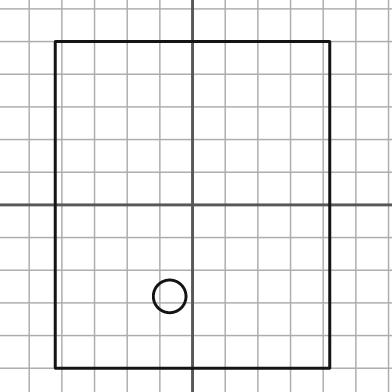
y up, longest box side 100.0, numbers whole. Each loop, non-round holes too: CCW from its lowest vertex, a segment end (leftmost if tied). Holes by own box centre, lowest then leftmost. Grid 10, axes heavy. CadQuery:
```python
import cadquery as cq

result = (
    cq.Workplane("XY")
    .moveTo(-42.0, -50.0)
    .lineTo(42.0, -50.0)
    .lineTo(42.0, 50.0)
    .lineTo(-42.0, 50.0)
    .close()
    .moveTo(-7.0, -28.0)
    .circle(5.0)
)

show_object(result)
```